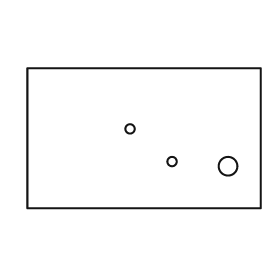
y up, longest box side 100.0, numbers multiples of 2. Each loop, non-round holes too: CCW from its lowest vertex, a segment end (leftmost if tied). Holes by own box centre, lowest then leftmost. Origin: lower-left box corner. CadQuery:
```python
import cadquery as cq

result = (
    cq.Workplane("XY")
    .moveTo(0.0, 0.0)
    .lineTo(100.0, 0.0)
    .lineTo(100.0, 60.0)
    .lineTo(0.0, 60.0)
    .close()
    .moveTo(86.0, 18.0)
    .circle(4.0)
    .moveTo(62.0, 20.0)
    .circle(2.0)
    .moveTo(44.0, 34.0)
    .circle(2.0)
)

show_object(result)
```